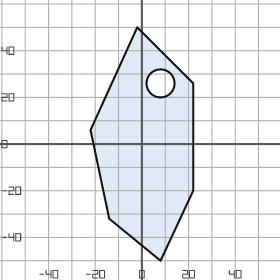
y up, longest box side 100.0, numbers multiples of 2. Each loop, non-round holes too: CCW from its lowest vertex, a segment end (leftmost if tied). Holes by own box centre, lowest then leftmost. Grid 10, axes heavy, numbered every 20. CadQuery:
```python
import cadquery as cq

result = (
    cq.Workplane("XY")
    .moveTo(8.0, -50.0)
    .lineTo(22.0, -20.0)
    .lineTo(22.0, 26.0)
    .lineTo(-2.0, 50.0)
    .lineTo(-22.0, 6.0)
    .lineTo(-14.0, -32.0)
    .close()
    .moveTo(8.0, 26.0)
    .circle(6.0)
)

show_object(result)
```